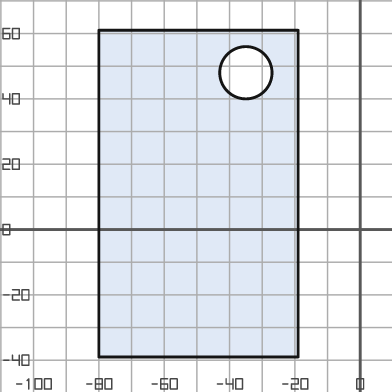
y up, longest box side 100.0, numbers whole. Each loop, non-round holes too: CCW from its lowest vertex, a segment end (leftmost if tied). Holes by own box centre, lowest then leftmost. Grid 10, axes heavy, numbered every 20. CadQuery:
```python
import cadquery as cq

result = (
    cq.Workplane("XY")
    .moveTo(-80.0, -39.0)
    .lineTo(-19.0, -39.0)
    .lineTo(-19.0, 61.0)
    .lineTo(-80.0, 61.0)
    .close()
    .moveTo(-35.0, 48.0)
    .circle(8.0)
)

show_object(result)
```